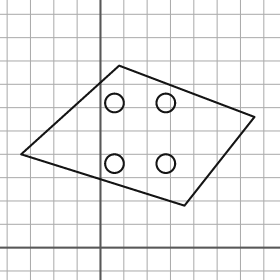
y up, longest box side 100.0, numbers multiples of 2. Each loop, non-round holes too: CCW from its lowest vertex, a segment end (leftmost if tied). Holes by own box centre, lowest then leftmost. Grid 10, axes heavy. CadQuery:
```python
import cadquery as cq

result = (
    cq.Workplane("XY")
    .moveTo(36.0, 18.0)
    .lineTo(66.0, 56.0)
    .lineTo(8.0, 78.0)
    .lineTo(-34.0, 40.0)
    .close()
    .moveTo(6.0, 36.0)
    .circle(4.0)
    .moveTo(28.0, 36.0)
    .circle(4.0)
    .moveTo(6.0, 62.0)
    .circle(4.0)
    .moveTo(28.0, 62.0)
    .circle(4.0)
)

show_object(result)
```